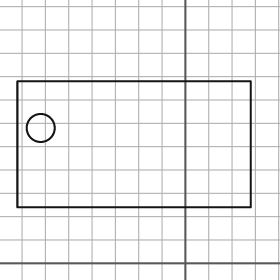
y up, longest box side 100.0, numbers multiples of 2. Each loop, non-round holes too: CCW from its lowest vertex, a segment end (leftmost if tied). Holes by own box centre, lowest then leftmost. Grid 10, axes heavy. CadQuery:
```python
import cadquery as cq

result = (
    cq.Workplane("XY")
    .moveTo(-72.0, 24.0)
    .lineTo(28.0, 24.0)
    .lineTo(28.0, 78.0)
    .lineTo(-72.0, 78.0)
    .close()
    .moveTo(-62.0, 58.0)
    .circle(6.0)
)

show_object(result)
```